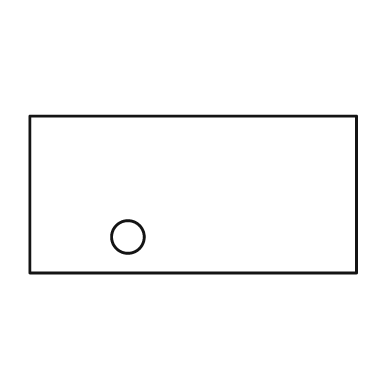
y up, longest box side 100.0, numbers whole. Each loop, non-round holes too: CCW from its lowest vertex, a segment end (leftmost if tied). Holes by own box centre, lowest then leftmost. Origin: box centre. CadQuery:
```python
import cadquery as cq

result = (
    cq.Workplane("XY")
    .moveTo(-50.0, -24.0)
    .lineTo(50.0, -24.0)
    .lineTo(50.0, 24.0)
    .lineTo(-50.0, 24.0)
    .close()
    .moveTo(-20.0, -13.0)
    .circle(5.0)
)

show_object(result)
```